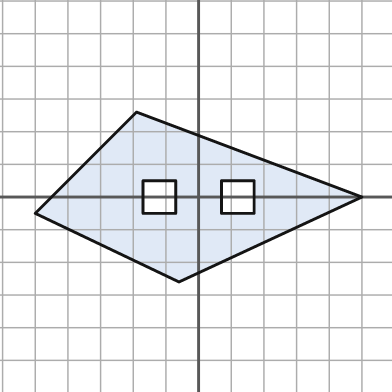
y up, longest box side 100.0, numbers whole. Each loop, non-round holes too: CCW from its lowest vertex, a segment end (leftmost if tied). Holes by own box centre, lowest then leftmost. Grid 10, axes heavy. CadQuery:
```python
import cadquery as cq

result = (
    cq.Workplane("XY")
    .moveTo(-6.0, -26.0)
    .lineTo(50.0, 0.0)
    .lineTo(-19.0, 26.0)
    .lineTo(-50.0, -5.0)
    .close()
    .moveTo(-17.0, -5.0)
    .lineTo(-7.0, -5.0)
    .lineTo(-7.0, 5.0)
    .lineTo(-17.0, 5.0)
    .close()
    .moveTo(7.0, -5.0)
    .lineTo(17.0, -5.0)
    .lineTo(17.0, 5.0)
    .lineTo(7.0, 5.0)
    .close()
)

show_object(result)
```